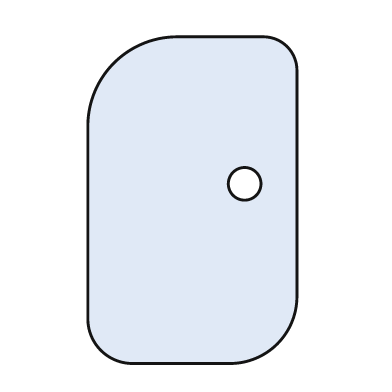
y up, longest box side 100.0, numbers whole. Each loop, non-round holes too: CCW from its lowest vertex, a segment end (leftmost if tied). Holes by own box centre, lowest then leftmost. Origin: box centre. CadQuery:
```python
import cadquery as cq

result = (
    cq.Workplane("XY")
    .moveTo(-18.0, -50.0)
    .lineTo(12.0, -50.0)
    .threePointArc((26.0, -44.0), (32.0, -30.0))
    .lineTo(32.0, 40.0)
    .threePointArc((29.0, 47.0), (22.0, 50.0))
    .lineTo(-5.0, 50.0)
    .threePointArc((-24.0, 42.0), (-32.0, 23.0))
    .lineTo(-32.0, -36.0)
    .threePointArc((-28.0, -46.0), (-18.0, -50.0))
    .close()
    .moveTo(16.0, 5.0)
    .circle(5.0)
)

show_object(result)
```